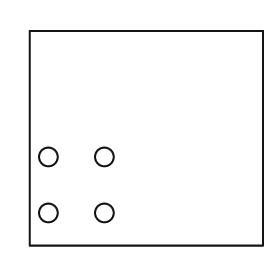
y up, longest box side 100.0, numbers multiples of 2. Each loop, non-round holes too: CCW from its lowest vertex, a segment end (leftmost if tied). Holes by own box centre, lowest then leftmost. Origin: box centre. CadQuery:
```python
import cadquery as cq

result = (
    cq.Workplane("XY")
    .moveTo(-50.0, -46.0)
    .lineTo(50.0, -46.0)
    .lineTo(50.0, 46.0)
    .lineTo(-50.0, 46.0)
    .close()
    .moveTo(-42.0, -32.0)
    .circle(4.0)
    .moveTo(-18.0, -32.0)
    .circle(4.0)
    .moveTo(-42.0, -8.0)
    .circle(4.0)
    .moveTo(-18.0, -8.0)
    .circle(4.0)
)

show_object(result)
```